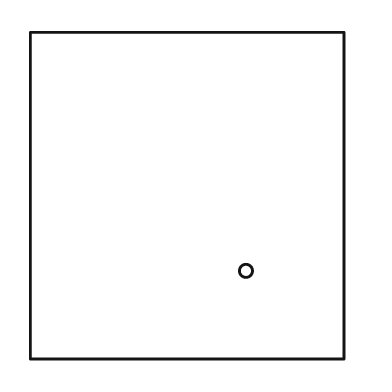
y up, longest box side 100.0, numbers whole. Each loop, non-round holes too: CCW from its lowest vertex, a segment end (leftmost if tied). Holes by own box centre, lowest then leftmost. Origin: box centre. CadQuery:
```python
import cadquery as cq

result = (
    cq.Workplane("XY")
    .moveTo(-48.0, -50.0)
    .lineTo(48.0, -50.0)
    .lineTo(48.0, 50.0)
    .lineTo(-48.0, 50.0)
    .close()
    .moveTo(18.0, -23.0)
    .circle(2.0)
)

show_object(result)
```